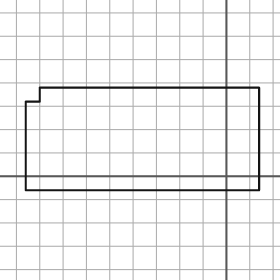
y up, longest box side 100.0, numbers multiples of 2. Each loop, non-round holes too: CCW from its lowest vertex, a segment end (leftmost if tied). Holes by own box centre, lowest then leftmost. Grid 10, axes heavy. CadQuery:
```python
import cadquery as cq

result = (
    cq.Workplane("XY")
    .moveTo(-86.0, -6.0)
    .lineTo(14.0, -6.0)
    .lineTo(14.0, 38.0)
    .lineTo(-80.0, 38.0)
    .lineTo(-80.0, 32.0)
    .lineTo(-86.0, 32.0)
    .close()
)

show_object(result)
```